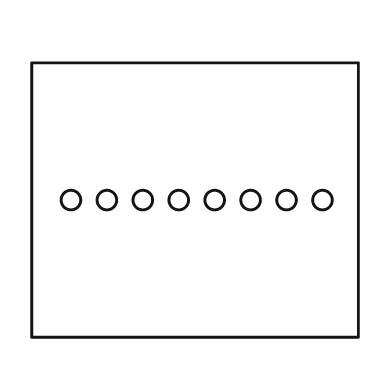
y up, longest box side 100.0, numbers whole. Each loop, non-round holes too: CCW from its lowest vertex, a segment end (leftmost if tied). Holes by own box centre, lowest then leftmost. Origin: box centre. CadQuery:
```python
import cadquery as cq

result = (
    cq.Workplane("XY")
    .moveTo(-50.0, -42.0)
    .lineTo(50.0, -42.0)
    .lineTo(50.0, 42.0)
    .lineTo(-50.0, 42.0)
    .close()
    .moveTo(-38.0, 0.0)
    .circle(3.0)
    .moveTo(-27.0, 0.0)
    .circle(3.0)
    .moveTo(-16.0, 0.0)
    .circle(3.0)
    .moveTo(-5.0, 0.0)
    .circle(3.0)
    .moveTo(6.0, 0.0)
    .circle(3.0)
    .moveTo(17.0, 0.0)
    .circle(3.0)
    .moveTo(28.0, 0.0)
    .circle(3.0)
    .moveTo(39.0, 0.0)
    .circle(3.0)
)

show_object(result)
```